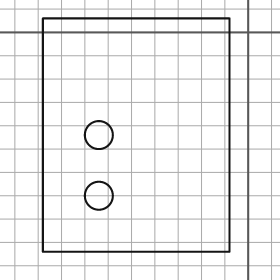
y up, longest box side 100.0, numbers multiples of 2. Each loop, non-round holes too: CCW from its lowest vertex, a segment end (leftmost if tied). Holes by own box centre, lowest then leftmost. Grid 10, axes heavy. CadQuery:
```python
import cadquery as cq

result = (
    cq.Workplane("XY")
    .moveTo(-88.0, -94.0)
    .lineTo(-8.0, -94.0)
    .lineTo(-8.0, 6.0)
    .lineTo(-88.0, 6.0)
    .close()
    .moveTo(-64.0, -70.0)
    .circle(6.0)
    .moveTo(-64.0, -44.0)
    .circle(6.0)
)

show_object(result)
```